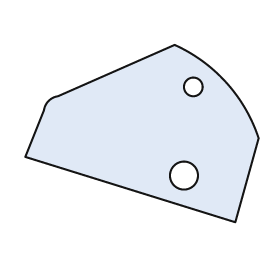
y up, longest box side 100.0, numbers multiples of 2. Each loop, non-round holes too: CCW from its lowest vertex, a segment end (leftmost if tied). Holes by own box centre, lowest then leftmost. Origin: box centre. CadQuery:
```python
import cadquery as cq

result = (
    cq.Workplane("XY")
    .moveTo(40.0, -38.0)
    .lineTo(50.0, -2.0)
    .threePointArc((36.0, 22.0), (14.0, 38.0))
    .lineTo(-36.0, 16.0)
    .threePointArc((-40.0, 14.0), (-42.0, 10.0))
    .lineTo(-50.0, -10.0)
    .close()
    .moveTo(18.0, -18.0)
    .circle(6.0)
    .moveTo(22.0, 20.0)
    .circle(4.0)
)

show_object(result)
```